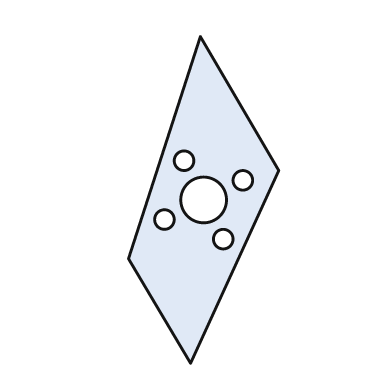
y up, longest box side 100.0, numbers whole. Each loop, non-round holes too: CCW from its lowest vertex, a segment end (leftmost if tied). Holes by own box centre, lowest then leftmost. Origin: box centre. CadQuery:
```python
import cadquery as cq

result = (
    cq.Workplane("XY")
    .moveTo(-4.0, -50.0)
    .lineTo(23.0, 9.0)
    .lineTo(-1.0, 50.0)
    .lineTo(-23.0, -18.0)
    .close()
    .moveTo(6.0, -12.0)
    .circle(3.0)
    .moveTo(-12.0, -6.0)
    .circle(3.0)
    .moveTo(0.0, 0.0)
    .circle(7.0)
    .moveTo(12.0, 6.0)
    .circle(3.0)
    .moveTo(-6.0, 12.0)
    .circle(3.0)
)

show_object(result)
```